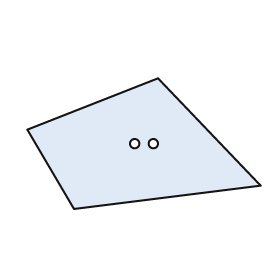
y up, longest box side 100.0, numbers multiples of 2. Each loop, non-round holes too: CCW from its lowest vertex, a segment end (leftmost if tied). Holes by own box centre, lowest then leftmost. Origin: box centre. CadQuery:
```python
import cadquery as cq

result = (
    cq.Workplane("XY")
    .moveTo(-30.0, -28.0)
    .lineTo(50.0, -18.0)
    .lineTo(6.0, 28.0)
    .lineTo(-50.0, 6.0)
    .close()
    .moveTo(-4.0, 0.0)
    .circle(2.0)
    .moveTo(4.0, 0.0)
    .circle(2.0)
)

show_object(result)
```